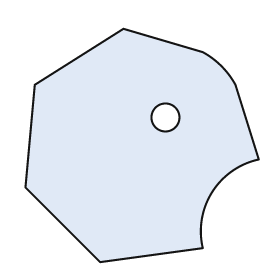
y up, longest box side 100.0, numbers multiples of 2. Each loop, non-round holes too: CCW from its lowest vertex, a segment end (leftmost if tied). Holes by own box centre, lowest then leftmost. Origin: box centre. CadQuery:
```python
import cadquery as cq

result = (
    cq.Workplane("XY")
    .moveTo(-18.0, -50.0)
    .lineTo(26.0, -44.0)
    .threePointArc((30.0, -20.0), (50.0, -6.0))
    .lineTo(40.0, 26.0)
    .threePointArc((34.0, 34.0), (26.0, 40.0))
    .lineTo(-8.0, 50.0)
    .lineTo(-46.0, 26.0)
    .lineTo(-50.0, -18.0)
    .close()
    .moveTo(10.0, 12.0)
    .circle(6.0)
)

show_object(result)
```